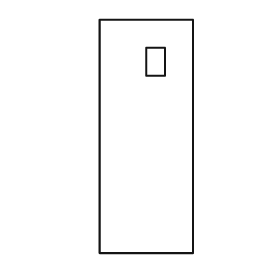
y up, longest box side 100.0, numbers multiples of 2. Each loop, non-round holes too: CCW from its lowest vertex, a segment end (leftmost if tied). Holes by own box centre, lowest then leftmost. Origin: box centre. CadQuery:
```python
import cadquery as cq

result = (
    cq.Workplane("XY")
    .moveTo(-20.0, -50.0)
    .lineTo(20.0, -50.0)
    .lineTo(20.0, 50.0)
    .lineTo(-20.0, 50.0)
    .close()
    .moveTo(0.0, 26.0)
    .lineTo(8.0, 26.0)
    .lineTo(8.0, 38.0)
    .lineTo(0.0, 38.0)
    .close()
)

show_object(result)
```